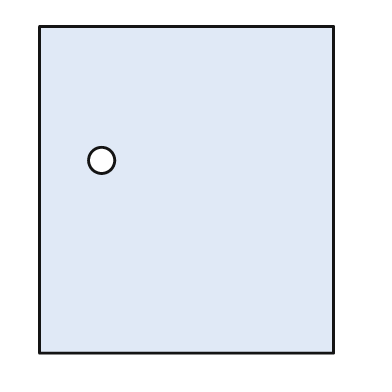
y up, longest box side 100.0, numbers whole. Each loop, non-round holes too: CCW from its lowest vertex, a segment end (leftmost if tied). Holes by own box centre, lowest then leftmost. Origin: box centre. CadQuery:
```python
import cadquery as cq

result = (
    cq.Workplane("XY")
    .moveTo(-45.0, -50.0)
    .lineTo(45.0, -50.0)
    .lineTo(45.0, 50.0)
    .lineTo(-45.0, 50.0)
    .close()
    .moveTo(-26.0, 9.0)
    .circle(4.0)
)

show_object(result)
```